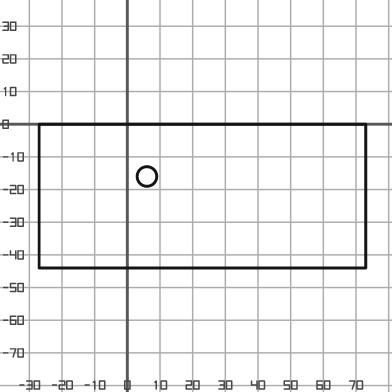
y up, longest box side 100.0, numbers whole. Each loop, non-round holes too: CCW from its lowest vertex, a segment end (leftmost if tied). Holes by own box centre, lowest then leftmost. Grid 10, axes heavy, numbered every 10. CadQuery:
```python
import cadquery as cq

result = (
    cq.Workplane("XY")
    .moveTo(-27.0, -44.0)
    .lineTo(73.0, -44.0)
    .lineTo(73.0, 0.0)
    .lineTo(-27.0, 0.0)
    .close()
    .moveTo(6.0, -16.0)
    .circle(3.0)
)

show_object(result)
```